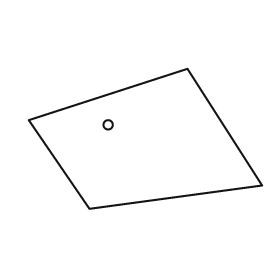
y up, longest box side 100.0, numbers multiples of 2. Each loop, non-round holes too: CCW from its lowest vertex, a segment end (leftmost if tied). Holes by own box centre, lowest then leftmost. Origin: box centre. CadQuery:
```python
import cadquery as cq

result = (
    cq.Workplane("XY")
    .moveTo(-24.0, -30.0)
    .lineTo(50.0, -20.0)
    .lineTo(18.0, 30.0)
    .lineTo(-50.0, 8.0)
    .close()
    .moveTo(-16.0, 6.0)
    .circle(2.0)
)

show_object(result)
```